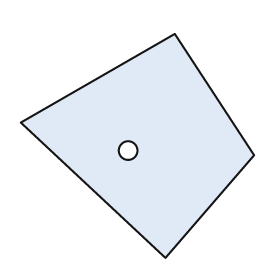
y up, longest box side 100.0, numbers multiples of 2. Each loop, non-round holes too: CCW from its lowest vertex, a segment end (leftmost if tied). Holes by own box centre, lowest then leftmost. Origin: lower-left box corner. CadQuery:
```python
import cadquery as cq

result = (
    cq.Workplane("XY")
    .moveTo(62.0, 0.0)
    .lineTo(100.0, 44.0)
    .lineTo(66.0, 96.0)
    .lineTo(0.0, 58.0)
    .close()
    .moveTo(46.0, 46.0)
    .circle(4.0)
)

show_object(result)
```